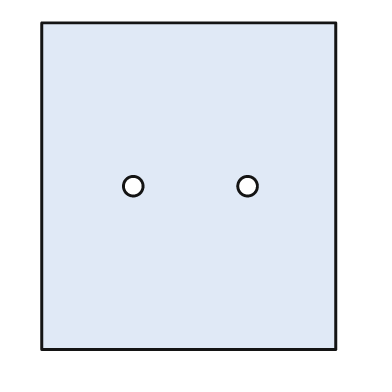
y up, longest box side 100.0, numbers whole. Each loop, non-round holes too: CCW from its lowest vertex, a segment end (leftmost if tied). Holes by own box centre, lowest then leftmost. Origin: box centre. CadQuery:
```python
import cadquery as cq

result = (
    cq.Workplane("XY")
    .moveTo(-45.0, -50.0)
    .lineTo(45.0, -50.0)
    .lineTo(45.0, 50.0)
    .lineTo(-45.0, 50.0)
    .close()
    .moveTo(-17.0, 0.0)
    .circle(3.0)
    .moveTo(18.0, 0.0)
    .circle(3.0)
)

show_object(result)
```